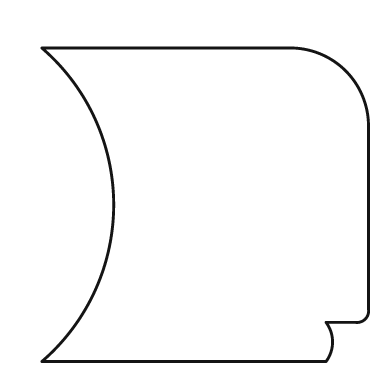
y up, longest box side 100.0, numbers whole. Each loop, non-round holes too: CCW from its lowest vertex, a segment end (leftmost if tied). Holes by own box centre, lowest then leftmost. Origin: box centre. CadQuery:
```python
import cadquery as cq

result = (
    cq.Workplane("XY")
    .moveTo(-50.0, -48.0)
    .lineTo(37.0, -48.0)
    .threePointArc((39.0, -42.0), (37.0, -36.0))
    .lineTo(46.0, -36.0)
    .threePointArc((49.0, -35.0), (50.0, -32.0))
    .lineTo(50.0, 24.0)
    .threePointArc((43.0, 41.0), (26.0, 48.0))
    .lineTo(-50.0, 48.0)
    .threePointArc((-28.0, 0.0), (-50.0, -48.0))
    .close()
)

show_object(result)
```